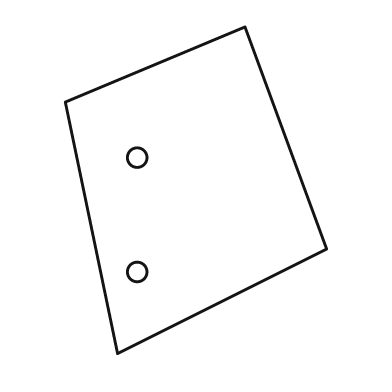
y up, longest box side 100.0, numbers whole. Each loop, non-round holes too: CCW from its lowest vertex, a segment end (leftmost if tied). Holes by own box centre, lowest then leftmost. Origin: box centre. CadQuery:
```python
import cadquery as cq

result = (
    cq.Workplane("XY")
    .moveTo(-24.0, -50.0)
    .lineTo(40.0, -18.0)
    .lineTo(15.0, 50.0)
    .lineTo(-40.0, 27.0)
    .close()
    .moveTo(-18.0, -25.0)
    .circle(3.0)
    .moveTo(-18.0, 10.0)
    .circle(3.0)
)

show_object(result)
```